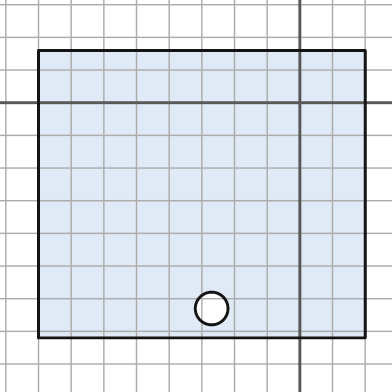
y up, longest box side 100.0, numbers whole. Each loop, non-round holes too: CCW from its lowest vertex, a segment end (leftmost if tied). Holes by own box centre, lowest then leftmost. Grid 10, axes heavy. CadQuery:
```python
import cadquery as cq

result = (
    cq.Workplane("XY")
    .moveTo(-80.0, -72.0)
    .lineTo(20.0, -72.0)
    .lineTo(20.0, 16.0)
    .lineTo(-80.0, 16.0)
    .close()
    .moveTo(-27.0, -63.0)
    .circle(5.0)
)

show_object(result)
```